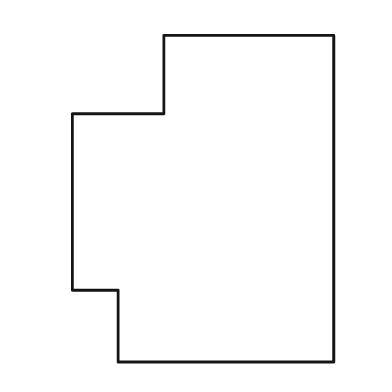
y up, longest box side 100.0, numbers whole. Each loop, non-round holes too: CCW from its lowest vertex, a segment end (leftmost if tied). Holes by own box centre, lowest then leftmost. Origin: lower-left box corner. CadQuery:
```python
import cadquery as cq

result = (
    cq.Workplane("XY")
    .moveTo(14.0, 0.0)
    .lineTo(80.0, 0.0)
    .lineTo(80.0, 100.0)
    .lineTo(28.0, 100.0)
    .lineTo(28.0, 76.0)
    .lineTo(0.0, 76.0)
    .lineTo(0.0, 22.0)
    .lineTo(14.0, 22.0)
    .close()
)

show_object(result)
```